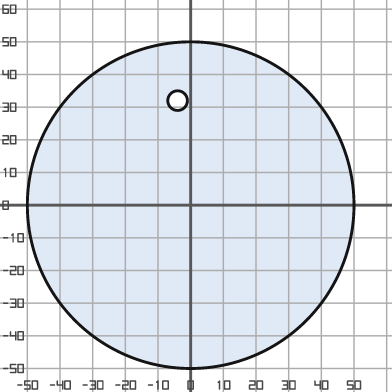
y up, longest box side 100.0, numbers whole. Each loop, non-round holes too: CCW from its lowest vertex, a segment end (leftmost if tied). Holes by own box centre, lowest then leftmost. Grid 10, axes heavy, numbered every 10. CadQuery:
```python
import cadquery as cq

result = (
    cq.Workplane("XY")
    .moveTo(0.0, 0.0)
    .circle(50.0)
    .moveTo(-4.0, 32.0)
    .circle(3.0)
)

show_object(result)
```